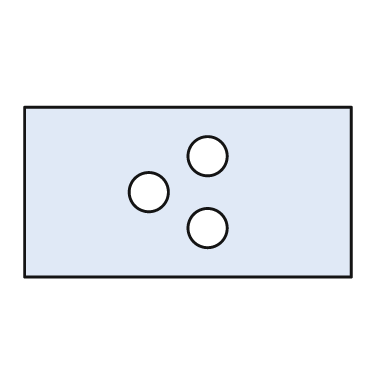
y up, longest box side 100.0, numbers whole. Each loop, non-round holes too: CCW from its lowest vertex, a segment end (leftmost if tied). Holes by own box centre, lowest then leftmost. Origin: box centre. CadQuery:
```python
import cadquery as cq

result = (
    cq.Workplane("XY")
    .moveTo(-50.0, -26.0)
    .lineTo(50.0, -26.0)
    .lineTo(50.0, 26.0)
    .lineTo(-50.0, 26.0)
    .close()
    .moveTo(6.0, -11.0)
    .circle(6.0)
    .moveTo(-12.0, 0.0)
    .circle(6.0)
    .moveTo(6.0, 11.0)
    .circle(6.0)
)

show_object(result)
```